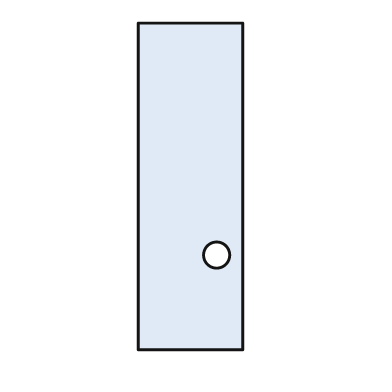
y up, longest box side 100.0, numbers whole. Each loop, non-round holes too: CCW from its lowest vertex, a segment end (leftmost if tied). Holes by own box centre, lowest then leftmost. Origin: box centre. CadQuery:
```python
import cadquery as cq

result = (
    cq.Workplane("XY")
    .moveTo(-16.0, -50.0)
    .lineTo(16.0, -50.0)
    .lineTo(16.0, 50.0)
    .lineTo(-16.0, 50.0)
    .close()
    .moveTo(8.0, -21.0)
    .circle(4.0)
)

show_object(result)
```